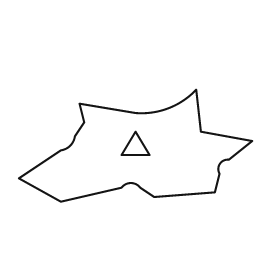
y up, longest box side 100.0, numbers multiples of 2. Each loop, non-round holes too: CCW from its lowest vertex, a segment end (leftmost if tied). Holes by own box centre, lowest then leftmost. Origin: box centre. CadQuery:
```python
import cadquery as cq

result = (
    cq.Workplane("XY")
    .moveTo(-32.0, -24.0)
    .lineTo(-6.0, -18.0)
    .threePointArc((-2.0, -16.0), (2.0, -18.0))
    .lineTo(8.0, -22.0)
    .lineTo(34.0, -20.0)
    .lineTo(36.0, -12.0)
    .threePointArc((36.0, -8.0), (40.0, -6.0))
    .lineTo(50.0, 2.0)
    .lineTo(28.0, 6.0)
    .lineTo(26.0, 24.0)
    .threePointArc((14.0, 16.0), (0.0, 14.0))
    .lineTo(-24.0, 18.0)
    .lineTo(-22.0, 10.0)
    .lineTo(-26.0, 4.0)
    .threePointArc((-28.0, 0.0), (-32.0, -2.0))
    .lineTo(-50.0, -14.0)
    .close()
    .moveTo(-6.0, -4.0)
    .lineTo(6.0, -4.0)
    .lineTo(0.0, 6.0)
    .close()
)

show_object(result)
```